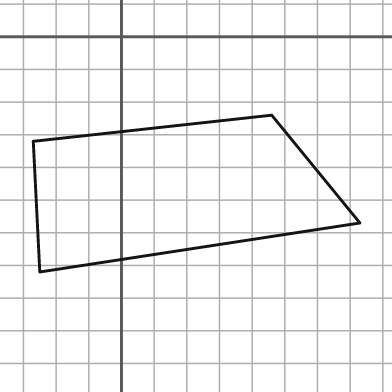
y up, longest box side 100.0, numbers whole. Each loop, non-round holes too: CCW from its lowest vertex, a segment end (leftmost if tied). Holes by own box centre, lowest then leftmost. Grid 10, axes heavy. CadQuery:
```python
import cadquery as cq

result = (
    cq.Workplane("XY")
    .moveTo(-25.0, -72.0)
    .lineTo(73.0, -57.0)
    .lineTo(46.0, -24.0)
    .lineTo(-27.0, -32.0)
    .close()
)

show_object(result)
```